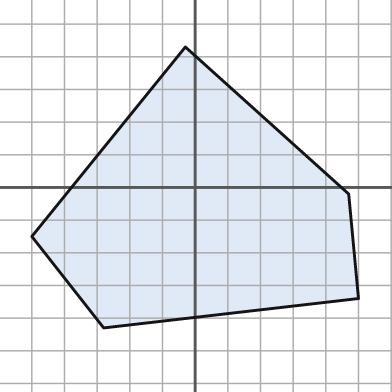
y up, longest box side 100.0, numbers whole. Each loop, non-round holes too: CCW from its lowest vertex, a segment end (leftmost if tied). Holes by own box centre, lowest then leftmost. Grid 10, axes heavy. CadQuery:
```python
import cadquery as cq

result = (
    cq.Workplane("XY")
    .moveTo(-28.0, -43.0)
    .lineTo(50.0, -34.0)
    .lineTo(47.0, -2.0)
    .lineTo(-3.0, 43.0)
    .lineTo(-50.0, -15.0)
    .close()
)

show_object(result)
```